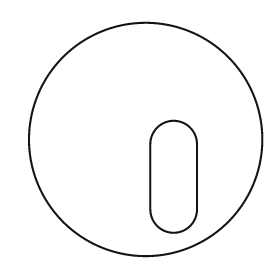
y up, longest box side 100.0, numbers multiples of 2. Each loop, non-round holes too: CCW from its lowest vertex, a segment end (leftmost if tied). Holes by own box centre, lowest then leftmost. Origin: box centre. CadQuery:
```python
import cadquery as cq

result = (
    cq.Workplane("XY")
    .moveTo(0.0, 0.0)
    .circle(50.0)
    .moveTo(2.0, -30.0)
    .threePointArc((12.0, -40.0), (22.0, -30.0))
    .lineTo(22.0, -2.0)
    .threePointArc((12.0, 8.0), (2.0, -2.0))
    .close()
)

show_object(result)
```